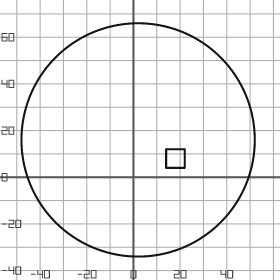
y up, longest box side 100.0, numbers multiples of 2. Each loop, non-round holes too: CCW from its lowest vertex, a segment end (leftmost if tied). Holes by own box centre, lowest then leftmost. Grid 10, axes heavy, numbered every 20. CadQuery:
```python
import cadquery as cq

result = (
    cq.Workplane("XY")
    .moveTo(2.0, 16.0)
    .circle(50.0)
    .moveTo(14.0, 4.0)
    .lineTo(22.0, 4.0)
    .lineTo(22.0, 12.0)
    .lineTo(14.0, 12.0)
    .close()
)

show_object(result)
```